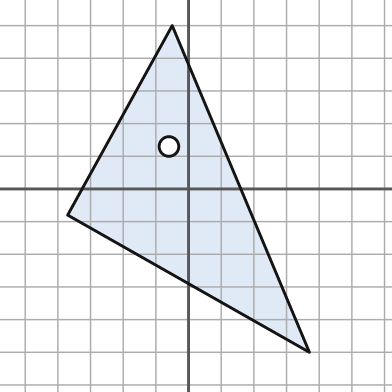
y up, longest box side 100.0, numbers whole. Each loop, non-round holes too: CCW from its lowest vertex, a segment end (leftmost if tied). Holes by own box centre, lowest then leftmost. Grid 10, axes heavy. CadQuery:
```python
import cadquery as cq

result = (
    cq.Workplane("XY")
    .moveTo(37.0, -50.0)
    .lineTo(-5.0, 50.0)
    .lineTo(-37.0, -8.0)
    .close()
    .moveTo(-6.0, 13.0)
    .circle(3.0)
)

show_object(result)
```